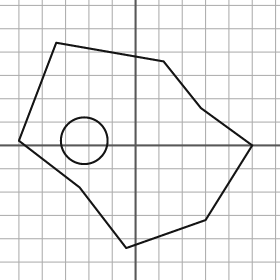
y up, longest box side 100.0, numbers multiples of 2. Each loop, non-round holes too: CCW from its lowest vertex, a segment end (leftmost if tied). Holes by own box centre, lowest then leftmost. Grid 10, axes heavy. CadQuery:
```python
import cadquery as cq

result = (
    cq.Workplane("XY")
    .moveTo(-4.0, -44.0)
    .lineTo(30.0, -32.0)
    .lineTo(50.0, 0.0)
    .lineTo(28.0, 16.0)
    .lineTo(12.0, 36.0)
    .lineTo(-34.0, 44.0)
    .lineTo(-50.0, 2.0)
    .lineTo(-24.0, -18.0)
    .close()
    .moveTo(-22.0, 2.0)
    .circle(10.0)
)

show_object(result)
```